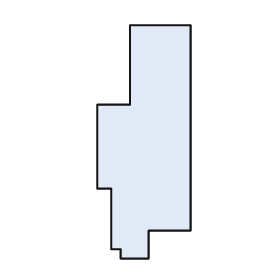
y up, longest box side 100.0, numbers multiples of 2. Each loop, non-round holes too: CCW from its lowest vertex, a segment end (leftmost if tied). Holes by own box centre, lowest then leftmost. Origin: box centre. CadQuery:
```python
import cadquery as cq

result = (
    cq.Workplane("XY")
    .moveTo(-10.0, -50.0)
    .lineTo(2.0, -50.0)
    .lineTo(2.0, -38.0)
    .lineTo(20.0, -38.0)
    .lineTo(20.0, 50.0)
    .lineTo(-6.0, 50.0)
    .lineTo(-6.0, 16.0)
    .lineTo(-20.0, 16.0)
    .lineTo(-20.0, -20.0)
    .lineTo(-14.0, -20.0)
    .lineTo(-14.0, -46.0)
    .lineTo(-10.0, -46.0)
    .close()
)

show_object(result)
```